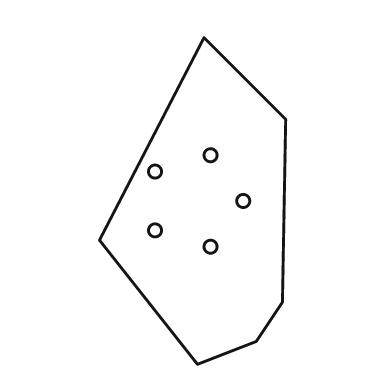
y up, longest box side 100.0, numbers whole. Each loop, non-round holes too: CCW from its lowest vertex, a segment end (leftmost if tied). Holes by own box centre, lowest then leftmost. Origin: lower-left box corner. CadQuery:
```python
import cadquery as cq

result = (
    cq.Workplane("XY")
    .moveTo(30.0, 0.0)
    .lineTo(48.0, 7.0)
    .lineTo(56.0, 19.0)
    .lineTo(57.0, 75.0)
    .lineTo(32.0, 100.0)
    .lineTo(0.0, 38.0)
    .close()
    .moveTo(34.0, 36.0)
    .circle(2.0)
    .moveTo(17.0, 41.0)
    .circle(2.0)
    .moveTo(44.0, 50.0)
    .circle(2.0)
    .moveTo(17.0, 59.0)
    .circle(2.0)
    .moveTo(34.0, 64.0)
    .circle(2.0)
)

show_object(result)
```